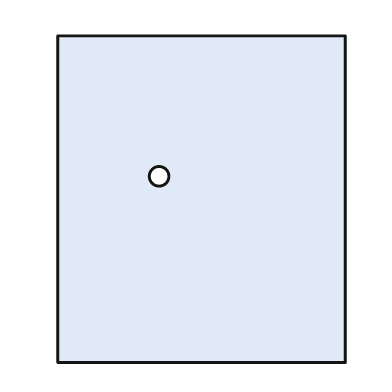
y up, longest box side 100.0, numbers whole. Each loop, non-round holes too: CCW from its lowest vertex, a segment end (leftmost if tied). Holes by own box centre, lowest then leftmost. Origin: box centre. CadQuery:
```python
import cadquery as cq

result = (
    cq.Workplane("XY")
    .moveTo(-44.0, -50.0)
    .lineTo(44.0, -50.0)
    .lineTo(44.0, 50.0)
    .lineTo(-44.0, 50.0)
    .close()
    .moveTo(-13.0, 7.0)
    .circle(3.0)
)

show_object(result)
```